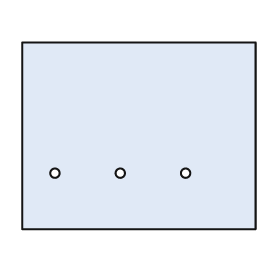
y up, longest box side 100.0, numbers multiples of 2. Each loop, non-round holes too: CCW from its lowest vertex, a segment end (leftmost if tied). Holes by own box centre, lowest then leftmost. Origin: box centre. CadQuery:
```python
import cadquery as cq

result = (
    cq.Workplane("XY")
    .moveTo(-50.0, -40.0)
    .lineTo(50.0, -40.0)
    .lineTo(50.0, 40.0)
    .lineTo(-50.0, 40.0)
    .close()
    .moveTo(-36.0, -16.0)
    .circle(2.0)
    .moveTo(-8.0, -16.0)
    .circle(2.0)
    .moveTo(20.0, -16.0)
    .circle(2.0)
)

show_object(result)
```